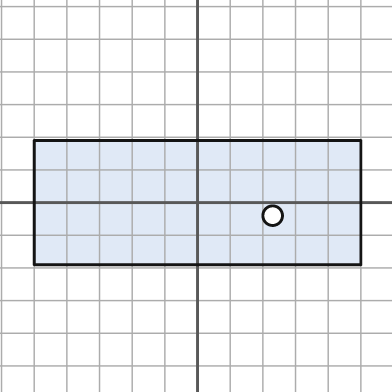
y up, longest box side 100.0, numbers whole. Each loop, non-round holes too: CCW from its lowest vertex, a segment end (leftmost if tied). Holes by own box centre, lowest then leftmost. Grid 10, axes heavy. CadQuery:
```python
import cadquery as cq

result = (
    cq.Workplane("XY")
    .moveTo(-50.0, -19.0)
    .lineTo(50.0, -19.0)
    .lineTo(50.0, 19.0)
    .lineTo(-50.0, 19.0)
    .close()
    .moveTo(23.0, -4.0)
    .circle(3.0)
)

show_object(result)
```